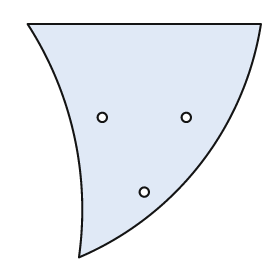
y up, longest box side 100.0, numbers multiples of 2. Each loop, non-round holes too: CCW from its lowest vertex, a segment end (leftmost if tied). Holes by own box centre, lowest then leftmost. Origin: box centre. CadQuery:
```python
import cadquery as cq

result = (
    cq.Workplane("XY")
    .moveTo(-28.0, -50.0)
    .threePointArc((24.0, -10.0), (50.0, 50.0))
    .lineTo(-50.0, 50.0)
    .threePointArc((-30.0, 2.0), (-28.0, -50.0))
    .close()
    .moveTo(0.0, -22.0)
    .circle(2.0)
    .moveTo(-18.0, 10.0)
    .circle(2.0)
    .moveTo(18.0, 10.0)
    .circle(2.0)
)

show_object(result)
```